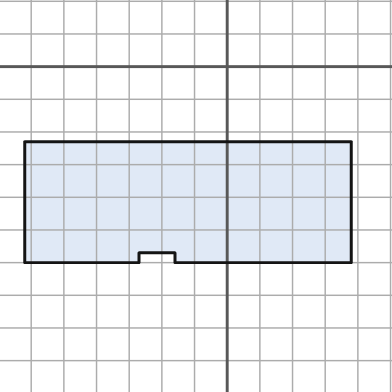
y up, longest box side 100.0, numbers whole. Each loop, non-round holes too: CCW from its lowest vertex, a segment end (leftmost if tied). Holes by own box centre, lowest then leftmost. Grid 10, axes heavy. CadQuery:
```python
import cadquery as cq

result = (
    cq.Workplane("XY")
    .moveTo(-62.0, -60.0)
    .lineTo(-27.0, -60.0)
    .lineTo(-27.0, -57.0)
    .lineTo(-16.0, -57.0)
    .lineTo(-16.0, -60.0)
    .lineTo(38.0, -60.0)
    .lineTo(38.0, -23.0)
    .lineTo(-62.0, -23.0)
    .close()
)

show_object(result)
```